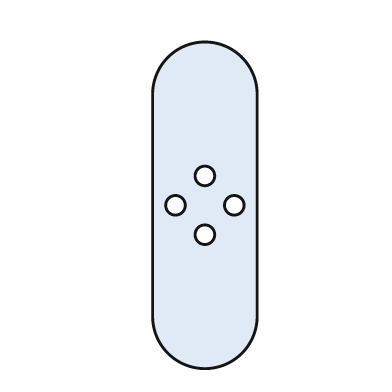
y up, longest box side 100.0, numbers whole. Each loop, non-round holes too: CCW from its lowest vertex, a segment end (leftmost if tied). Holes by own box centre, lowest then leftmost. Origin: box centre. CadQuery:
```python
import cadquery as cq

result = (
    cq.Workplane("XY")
    .moveTo(-16.0, -34.0)
    .threePointArc((0.0, -50.0), (16.0, -34.0))
    .lineTo(16.0, 34.0)
    .threePointArc((0.0, 50.0), (-16.0, 34.0))
    .close()
    .moveTo(0.0, -9.0)
    .circle(3.0)
    .moveTo(-9.0, 0.0)
    .circle(3.0)
    .moveTo(9.0, 0.0)
    .circle(3.0)
    .moveTo(0.0, 9.0)
    .circle(3.0)
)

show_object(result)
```